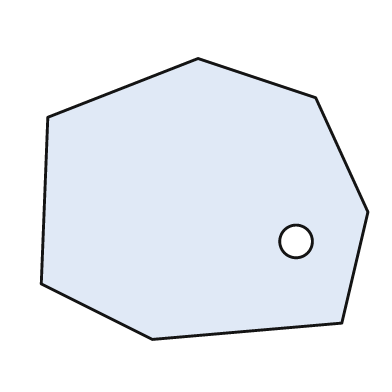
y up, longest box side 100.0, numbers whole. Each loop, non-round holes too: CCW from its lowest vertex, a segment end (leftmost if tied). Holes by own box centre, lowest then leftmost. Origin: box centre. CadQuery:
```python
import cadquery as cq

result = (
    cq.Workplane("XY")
    .moveTo(-16.0, -43.0)
    .lineTo(42.0, -38.0)
    .lineTo(50.0, -4.0)
    .lineTo(34.0, 31.0)
    .lineTo(-2.0, 43.0)
    .lineTo(-48.0, 25.0)
    .lineTo(-50.0, -26.0)
    .close()
    .moveTo(28.0, -13.0)
    .circle(5.0)
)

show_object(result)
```